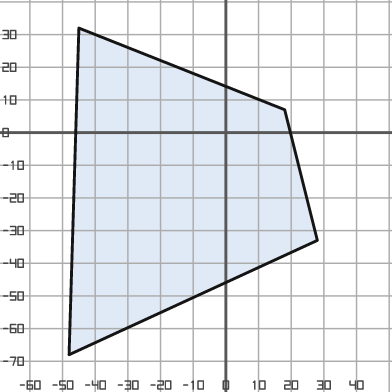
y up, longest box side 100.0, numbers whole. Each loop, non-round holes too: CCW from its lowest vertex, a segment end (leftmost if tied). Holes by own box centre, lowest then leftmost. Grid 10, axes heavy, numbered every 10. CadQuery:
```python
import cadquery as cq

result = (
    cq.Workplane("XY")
    .moveTo(-48.0, -68.0)
    .lineTo(28.0, -33.0)
    .lineTo(18.0, 7.0)
    .lineTo(-45.0, 32.0)
    .close()
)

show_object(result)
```